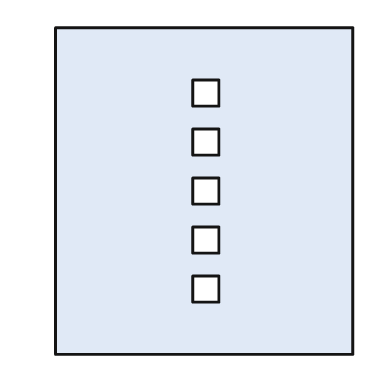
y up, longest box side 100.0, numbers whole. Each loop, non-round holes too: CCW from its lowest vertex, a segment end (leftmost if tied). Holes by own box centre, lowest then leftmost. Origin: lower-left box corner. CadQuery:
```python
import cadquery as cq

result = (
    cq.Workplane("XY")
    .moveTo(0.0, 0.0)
    .lineTo(91.0, 0.0)
    .lineTo(91.0, 100.0)
    .lineTo(0.0, 100.0)
    .close()
    .moveTo(42.0, 16.0)
    .lineTo(50.0, 16.0)
    .lineTo(50.0, 24.0)
    .lineTo(42.0, 24.0)
    .close()
    .moveTo(42.0, 31.0)
    .lineTo(50.0, 31.0)
    .lineTo(50.0, 39.0)
    .lineTo(42.0, 39.0)
    .close()
    .moveTo(42.0, 46.0)
    .lineTo(50.0, 46.0)
    .lineTo(50.0, 54.0)
    .lineTo(42.0, 54.0)
    .close()
    .moveTo(42.0, 61.0)
    .lineTo(50.0, 61.0)
    .lineTo(50.0, 69.0)
    .lineTo(42.0, 69.0)
    .close()
    .moveTo(42.0, 76.0)
    .lineTo(50.0, 76.0)
    .lineTo(50.0, 84.0)
    .lineTo(42.0, 84.0)
    .close()
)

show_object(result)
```